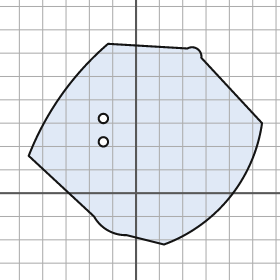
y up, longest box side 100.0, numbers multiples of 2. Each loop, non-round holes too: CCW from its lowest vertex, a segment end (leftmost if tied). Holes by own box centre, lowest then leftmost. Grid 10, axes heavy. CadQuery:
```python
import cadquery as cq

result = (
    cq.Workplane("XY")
    .moveTo(12.0, -22.0)
    .threePointArc((40.0, -2.0), (54.0, 30.0))
    .lineTo(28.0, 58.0)
    .threePointArc((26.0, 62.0), (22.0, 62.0))
    .lineTo(-12.0, 64.0)
    .threePointArc((-32.0, 42.0), (-46.0, 16.0))
    .lineTo(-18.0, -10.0)
    .threePointArc((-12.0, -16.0), (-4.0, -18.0))
    .close()
    .moveTo(-14.0, 22.0)
    .circle(2.0)
    .moveTo(-14.0, 32.0)
    .circle(2.0)
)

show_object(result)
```